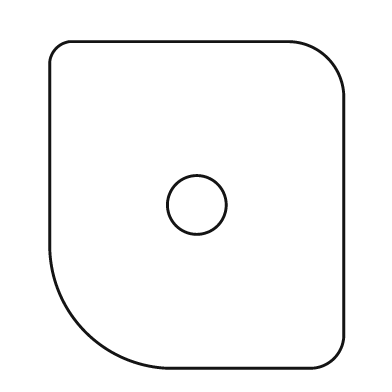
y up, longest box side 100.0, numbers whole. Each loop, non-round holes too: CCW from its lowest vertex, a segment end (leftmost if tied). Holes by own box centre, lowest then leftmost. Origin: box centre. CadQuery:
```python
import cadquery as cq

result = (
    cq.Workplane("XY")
    .moveTo(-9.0, -50.0)
    .lineTo(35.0, -50.0)
    .threePointArc((42.0, -47.0), (45.0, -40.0))
    .lineTo(45.0, 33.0)
    .threePointArc((40.0, 45.0), (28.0, 50.0))
    .lineTo(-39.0, 50.0)
    .threePointArc((-43.0, 48.0), (-45.0, 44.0))
    .lineTo(-45.0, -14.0)
    .threePointArc((-34.0, -39.0), (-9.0, -50.0))
    .close()
    .moveTo(0.0, 0.0)
    .circle(9.0)
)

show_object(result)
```